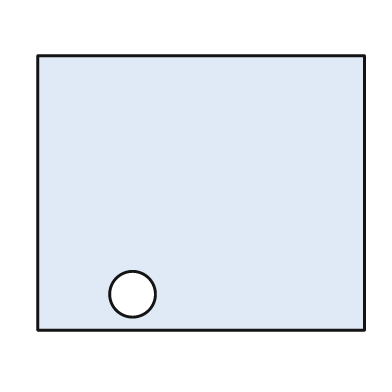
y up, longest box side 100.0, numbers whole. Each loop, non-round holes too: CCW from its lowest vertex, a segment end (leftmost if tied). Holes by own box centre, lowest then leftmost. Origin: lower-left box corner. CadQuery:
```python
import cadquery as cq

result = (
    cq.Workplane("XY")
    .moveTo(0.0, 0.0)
    .lineTo(100.0, 0.0)
    .lineTo(100.0, 84.0)
    .lineTo(0.0, 84.0)
    .close()
    .moveTo(29.0, 11.0)
    .circle(7.0)
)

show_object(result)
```